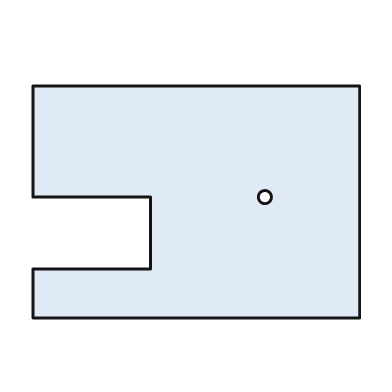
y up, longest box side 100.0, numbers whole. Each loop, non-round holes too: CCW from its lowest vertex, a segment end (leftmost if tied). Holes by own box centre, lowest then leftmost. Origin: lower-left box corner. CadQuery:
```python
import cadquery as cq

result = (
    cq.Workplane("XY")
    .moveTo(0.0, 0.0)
    .lineTo(100.0, 0.0)
    .lineTo(100.0, 71.0)
    .lineTo(0.0, 71.0)
    .lineTo(0.0, 37.0)
    .lineTo(36.0, 37.0)
    .lineTo(36.0, 15.0)
    .lineTo(0.0, 15.0)
    .close()
    .moveTo(71.0, 37.0)
    .circle(2.0)
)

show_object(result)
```